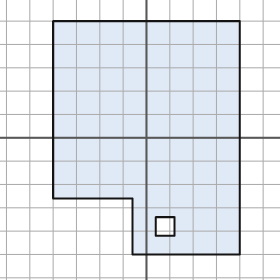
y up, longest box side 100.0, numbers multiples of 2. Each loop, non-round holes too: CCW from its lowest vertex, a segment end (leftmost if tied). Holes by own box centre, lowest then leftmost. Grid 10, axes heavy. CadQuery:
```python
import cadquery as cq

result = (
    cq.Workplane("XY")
    .moveTo(-6.0, -50.0)
    .lineTo(40.0, -50.0)
    .lineTo(40.0, 50.0)
    .lineTo(-40.0, 50.0)
    .lineTo(-40.0, -26.0)
    .lineTo(-6.0, -26.0)
    .close()
    .moveTo(4.0, -42.0)
    .lineTo(12.0, -42.0)
    .lineTo(12.0, -34.0)
    .lineTo(4.0, -34.0)
    .close()
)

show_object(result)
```